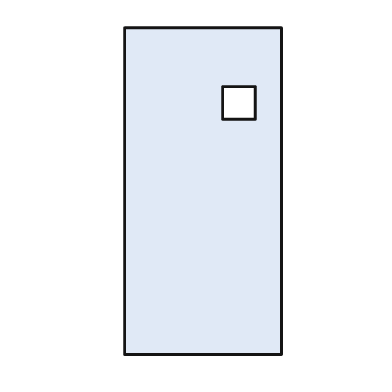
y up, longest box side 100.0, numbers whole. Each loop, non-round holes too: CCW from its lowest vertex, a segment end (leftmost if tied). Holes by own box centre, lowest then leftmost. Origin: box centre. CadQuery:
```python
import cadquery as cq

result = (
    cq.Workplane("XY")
    .moveTo(-24.0, -50.0)
    .lineTo(24.0, -50.0)
    .lineTo(24.0, 50.0)
    .lineTo(-24.0, 50.0)
    .close()
    .moveTo(6.0, 22.0)
    .lineTo(16.0, 22.0)
    .lineTo(16.0, 32.0)
    .lineTo(6.0, 32.0)
    .close()
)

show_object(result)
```